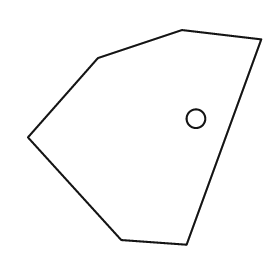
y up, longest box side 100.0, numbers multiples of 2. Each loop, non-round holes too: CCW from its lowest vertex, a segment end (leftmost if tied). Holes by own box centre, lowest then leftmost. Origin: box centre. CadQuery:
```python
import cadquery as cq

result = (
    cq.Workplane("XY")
    .moveTo(18.0, -46.0)
    .lineTo(50.0, 42.0)
    .lineTo(16.0, 46.0)
    .lineTo(-20.0, 34.0)
    .lineTo(-50.0, 0.0)
    .lineTo(-10.0, -44.0)
    .close()
    .moveTo(22.0, 8.0)
    .circle(4.0)
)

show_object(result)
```